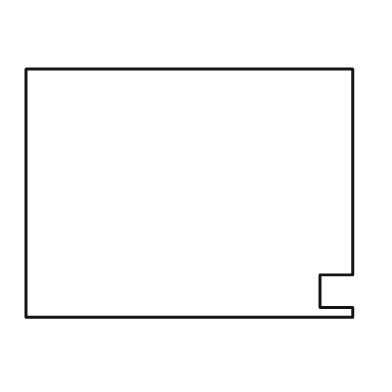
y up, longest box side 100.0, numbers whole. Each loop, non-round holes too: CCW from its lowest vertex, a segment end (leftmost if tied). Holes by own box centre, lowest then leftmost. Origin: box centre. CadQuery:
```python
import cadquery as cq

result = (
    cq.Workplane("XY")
    .moveTo(-50.0, -38.0)
    .lineTo(50.0, -38.0)
    .lineTo(50.0, -35.0)
    .lineTo(40.0, -35.0)
    .lineTo(40.0, -25.0)
    .lineTo(50.0, -25.0)
    .lineTo(50.0, 38.0)
    .lineTo(-50.0, 38.0)
    .close()
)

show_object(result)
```